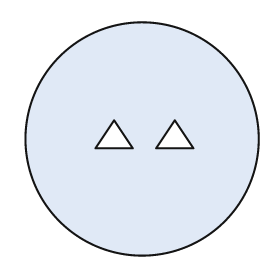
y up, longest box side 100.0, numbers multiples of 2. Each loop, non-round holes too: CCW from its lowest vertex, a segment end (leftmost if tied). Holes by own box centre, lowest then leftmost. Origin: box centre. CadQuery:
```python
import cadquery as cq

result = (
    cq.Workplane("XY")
    .moveTo(0.0, 0.0)
    .circle(50.0)
    .moveTo(-20.0, -4.0)
    .lineTo(-4.0, -4.0)
    .lineTo(-12.0, 8.0)
    .close()
    .moveTo(6.0, -4.0)
    .lineTo(22.0, -4.0)
    .lineTo(14.0, 8.0)
    .close()
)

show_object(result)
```